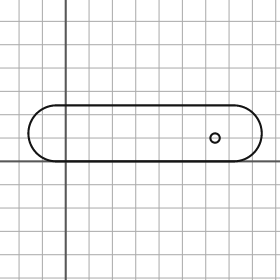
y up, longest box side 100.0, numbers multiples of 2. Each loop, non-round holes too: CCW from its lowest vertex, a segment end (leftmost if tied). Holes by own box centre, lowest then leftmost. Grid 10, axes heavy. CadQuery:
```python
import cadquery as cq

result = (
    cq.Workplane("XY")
    .moveTo(-4.0, 0.0)
    .lineTo(72.0, 0.0)
    .threePointArc((84.0, 12.0), (72.0, 24.0))
    .lineTo(-4.0, 24.0)
    .threePointArc((-16.0, 12.0), (-4.0, 0.0))
    .close()
    .moveTo(64.0, 10.0)
    .circle(2.0)
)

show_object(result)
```